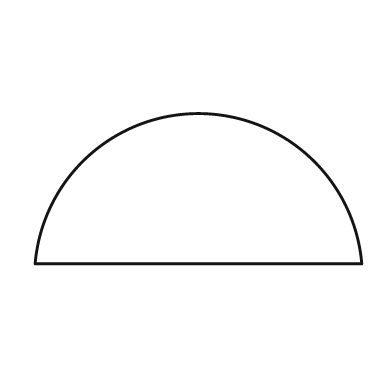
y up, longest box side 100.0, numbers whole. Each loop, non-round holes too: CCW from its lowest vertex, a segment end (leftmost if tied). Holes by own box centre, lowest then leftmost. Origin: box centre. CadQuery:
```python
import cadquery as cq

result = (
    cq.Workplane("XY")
    .moveTo(-50.0, -23.0)
    .lineTo(50.0, -23.0)
    .threePointArc((0.0, 23.0), (-50.0, -23.0))
    .close()
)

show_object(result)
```